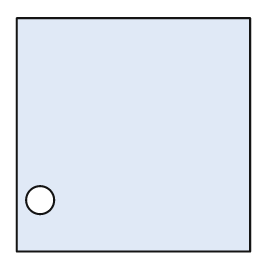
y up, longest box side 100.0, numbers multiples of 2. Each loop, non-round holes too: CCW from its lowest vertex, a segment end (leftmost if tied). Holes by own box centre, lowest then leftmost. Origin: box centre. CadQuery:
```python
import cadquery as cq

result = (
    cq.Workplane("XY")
    .moveTo(-50.0, -50.0)
    .lineTo(50.0, -50.0)
    .lineTo(50.0, 50.0)
    .lineTo(-50.0, 50.0)
    .close()
    .moveTo(-40.0, -28.0)
    .circle(6.0)
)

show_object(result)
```